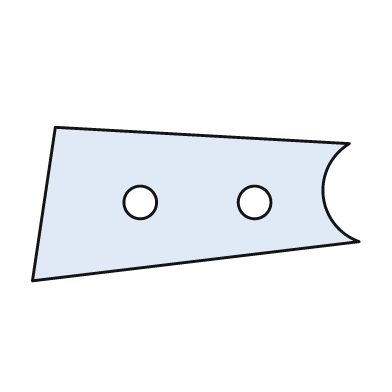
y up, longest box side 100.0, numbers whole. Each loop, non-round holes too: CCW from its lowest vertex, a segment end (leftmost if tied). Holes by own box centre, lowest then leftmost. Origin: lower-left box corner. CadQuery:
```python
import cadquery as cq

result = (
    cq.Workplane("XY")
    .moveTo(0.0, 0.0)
    .lineTo(100.0, 12.0)
    .threePointArc((89.0, 26.0), (97.0, 42.0))
    .lineTo(7.0, 47.0)
    .close()
    .moveTo(33.0, 24.0)
    .circle(5.0)
    .moveTo(68.0, 24.0)
    .circle(5.0)
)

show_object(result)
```